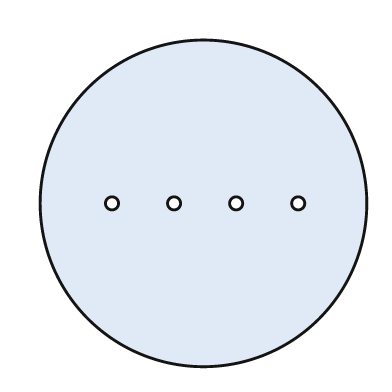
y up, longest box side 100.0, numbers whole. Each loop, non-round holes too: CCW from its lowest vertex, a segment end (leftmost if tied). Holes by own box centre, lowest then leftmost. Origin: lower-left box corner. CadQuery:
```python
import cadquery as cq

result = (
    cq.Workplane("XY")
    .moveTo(50.0, 50.0)
    .circle(50.0)
    .moveTo(22.0, 50.0)
    .circle(2.0)
    .moveTo(41.0, 50.0)
    .circle(2.0)
    .moveTo(60.0, 50.0)
    .circle(2.0)
    .moveTo(79.0, 50.0)
    .circle(2.0)
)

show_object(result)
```